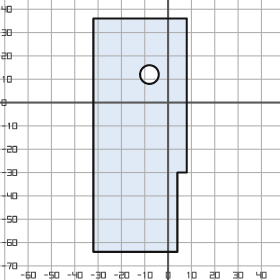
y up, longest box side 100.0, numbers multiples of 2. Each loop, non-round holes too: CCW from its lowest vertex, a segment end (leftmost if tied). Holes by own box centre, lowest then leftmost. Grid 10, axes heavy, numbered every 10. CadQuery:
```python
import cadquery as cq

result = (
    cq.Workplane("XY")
    .moveTo(-32.0, -64.0)
    .lineTo(4.0, -64.0)
    .lineTo(4.0, -30.0)
    .lineTo(8.0, -30.0)
    .lineTo(8.0, 36.0)
    .lineTo(-32.0, 36.0)
    .close()
    .moveTo(-8.0, 12.0)
    .circle(4.0)
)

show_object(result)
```